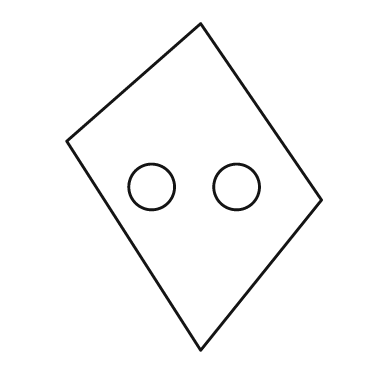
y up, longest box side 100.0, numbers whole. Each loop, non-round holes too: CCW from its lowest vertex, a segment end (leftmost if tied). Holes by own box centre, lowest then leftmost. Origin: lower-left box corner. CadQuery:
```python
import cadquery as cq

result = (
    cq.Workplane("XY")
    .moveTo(41.0, 0.0)
    .lineTo(78.0, 46.0)
    .lineTo(41.0, 100.0)
    .lineTo(0.0, 64.0)
    .close()
    .moveTo(26.0, 50.0)
    .circle(7.0)
    .moveTo(52.0, 50.0)
    .circle(7.0)
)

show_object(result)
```